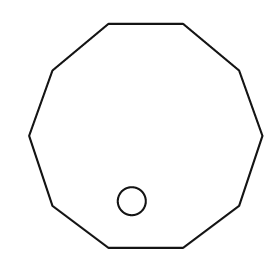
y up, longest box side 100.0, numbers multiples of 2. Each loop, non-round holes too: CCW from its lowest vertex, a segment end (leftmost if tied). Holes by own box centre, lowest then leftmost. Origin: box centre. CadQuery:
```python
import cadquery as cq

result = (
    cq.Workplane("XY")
    .moveTo(-16.0, -48.0)
    .lineTo(16.0, -48.0)
    .lineTo(40.0, -30.0)
    .lineTo(50.0, 0.0)
    .lineTo(40.0, 28.0)
    .lineTo(16.0, 48.0)
    .lineTo(-16.0, 48.0)
    .lineTo(-40.0, 28.0)
    .lineTo(-50.0, 0.0)
    .lineTo(-40.0, -30.0)
    .close()
    .moveTo(-6.0, -28.0)
    .circle(6.0)
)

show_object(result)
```